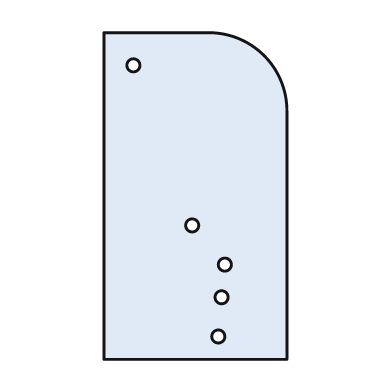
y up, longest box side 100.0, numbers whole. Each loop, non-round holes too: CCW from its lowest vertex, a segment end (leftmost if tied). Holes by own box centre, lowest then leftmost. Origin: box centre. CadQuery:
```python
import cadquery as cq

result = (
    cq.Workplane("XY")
    .moveTo(-28.0, -50.0)
    .lineTo(28.0, -50.0)
    .lineTo(28.0, 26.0)
    .threePointArc((21.0, 43.0), (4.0, 50.0))
    .lineTo(-28.0, 50.0)
    .close()
    .moveTo(7.0, -43.0)
    .circle(2.0)
    .moveTo(8.0, -31.0)
    .circle(2.0)
    .moveTo(9.0, -21.0)
    .circle(2.0)
    .moveTo(-1.0, -9.0)
    .circle(2.0)
    .moveTo(-19.0, 40.0)
    .circle(2.0)
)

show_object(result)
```